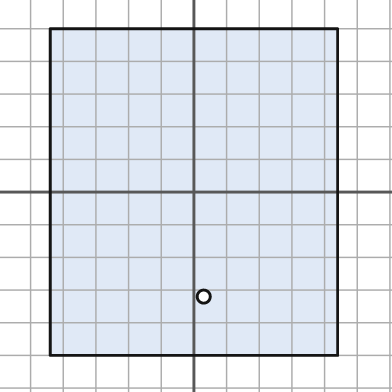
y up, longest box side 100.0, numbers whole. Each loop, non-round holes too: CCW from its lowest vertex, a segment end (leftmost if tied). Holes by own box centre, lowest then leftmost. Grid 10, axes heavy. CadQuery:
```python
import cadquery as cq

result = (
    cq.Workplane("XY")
    .moveTo(-44.0, -50.0)
    .lineTo(44.0, -50.0)
    .lineTo(44.0, 50.0)
    .lineTo(-44.0, 50.0)
    .close()
    .moveTo(3.0, -32.0)
    .circle(2.0)
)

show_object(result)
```